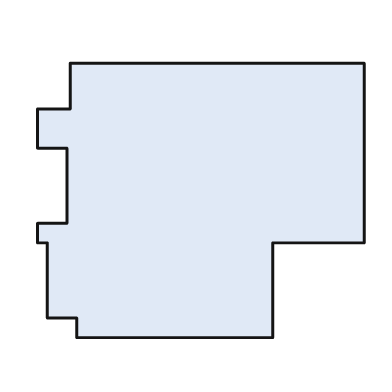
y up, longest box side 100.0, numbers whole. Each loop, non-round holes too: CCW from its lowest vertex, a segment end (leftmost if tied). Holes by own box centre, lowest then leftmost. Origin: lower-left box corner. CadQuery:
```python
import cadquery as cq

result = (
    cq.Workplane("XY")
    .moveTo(12.0, 0.0)
    .lineTo(72.0, 0.0)
    .lineTo(72.0, 29.0)
    .lineTo(100.0, 29.0)
    .lineTo(100.0, 84.0)
    .lineTo(10.0, 84.0)
    .lineTo(10.0, 70.0)
    .lineTo(0.0, 70.0)
    .lineTo(0.0, 58.0)
    .lineTo(9.0, 58.0)
    .lineTo(9.0, 35.0)
    .lineTo(0.0, 35.0)
    .lineTo(0.0, 29.0)
    .lineTo(3.0, 29.0)
    .lineTo(3.0, 6.0)
    .lineTo(12.0, 6.0)
    .close()
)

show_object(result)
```